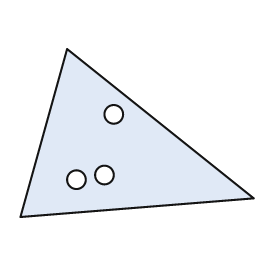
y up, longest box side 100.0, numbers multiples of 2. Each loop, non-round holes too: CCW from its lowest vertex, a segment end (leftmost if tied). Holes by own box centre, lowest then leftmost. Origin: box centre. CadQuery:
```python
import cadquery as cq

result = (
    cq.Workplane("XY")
    .moveTo(-50.0, -36.0)
    .lineTo(50.0, -28.0)
    .lineTo(-30.0, 36.0)
    .close()
    .moveTo(-26.0, -20.0)
    .circle(4.0)
    .moveTo(-14.0, -18.0)
    .circle(4.0)
    .moveTo(-10.0, 8.0)
    .circle(4.0)
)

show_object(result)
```